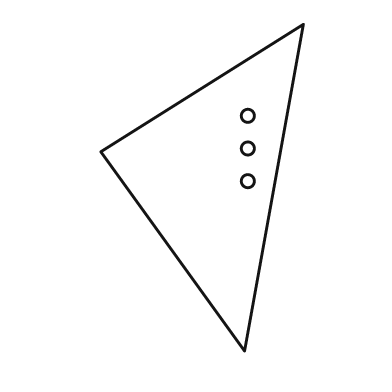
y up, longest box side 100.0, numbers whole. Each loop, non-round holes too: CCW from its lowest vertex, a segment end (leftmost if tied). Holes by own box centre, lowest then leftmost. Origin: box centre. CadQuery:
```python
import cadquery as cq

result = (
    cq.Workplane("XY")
    .moveTo(13.0, -50.0)
    .lineTo(31.0, 50.0)
    .lineTo(-31.0, 11.0)
    .close()
    .moveTo(14.0, 2.0)
    .circle(2.0)
    .moveTo(14.0, 12.0)
    .circle(2.0)
    .moveTo(14.0, 22.0)
    .circle(2.0)
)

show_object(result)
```